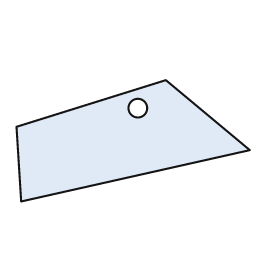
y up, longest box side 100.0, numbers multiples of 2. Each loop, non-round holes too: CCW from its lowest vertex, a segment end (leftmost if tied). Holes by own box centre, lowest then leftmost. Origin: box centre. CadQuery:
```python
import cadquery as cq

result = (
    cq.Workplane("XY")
    .moveTo(-48.0, -26.0)
    .lineTo(50.0, -4.0)
    .lineTo(14.0, 26.0)
    .lineTo(-50.0, 6.0)
    .close()
    .moveTo(2.0, 14.0)
    .circle(4.0)
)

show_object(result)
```